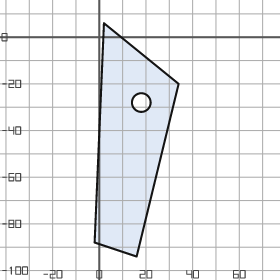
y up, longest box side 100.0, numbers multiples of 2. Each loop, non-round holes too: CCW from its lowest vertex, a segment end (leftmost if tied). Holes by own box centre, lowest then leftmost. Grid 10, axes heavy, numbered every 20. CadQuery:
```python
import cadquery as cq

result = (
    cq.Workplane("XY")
    .moveTo(16.0, -94.0)
    .lineTo(34.0, -20.0)
    .lineTo(2.0, 6.0)
    .lineTo(-2.0, -88.0)
    .close()
    .moveTo(18.0, -28.0)
    .circle(4.0)
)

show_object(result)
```